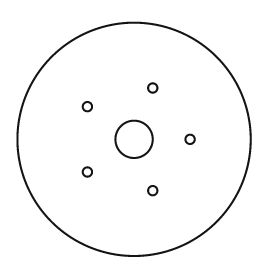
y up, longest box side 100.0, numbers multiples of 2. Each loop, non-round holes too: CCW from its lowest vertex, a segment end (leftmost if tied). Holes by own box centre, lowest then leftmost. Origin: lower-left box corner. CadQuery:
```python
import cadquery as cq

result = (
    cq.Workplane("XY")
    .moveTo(50.0, 50.0)
    .circle(50.0)
    .moveTo(58.0, 28.0)
    .circle(2.0)
    .moveTo(30.0, 36.0)
    .circle(2.0)
    .moveTo(50.0, 50.0)
    .circle(8.0)
    .moveTo(74.0, 50.0)
    .circle(2.0)
    .moveTo(30.0, 64.0)
    .circle(2.0)
    .moveTo(58.0, 72.0)
    .circle(2.0)
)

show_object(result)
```